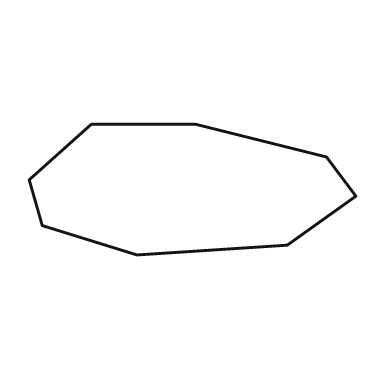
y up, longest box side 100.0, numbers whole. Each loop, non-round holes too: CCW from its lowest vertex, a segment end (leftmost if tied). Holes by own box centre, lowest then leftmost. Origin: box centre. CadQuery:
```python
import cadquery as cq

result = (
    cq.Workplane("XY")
    .moveTo(-17.0, -20.0)
    .lineTo(29.0, -17.0)
    .lineTo(50.0, -2.0)
    .lineTo(41.0, 10.0)
    .lineTo(1.0, 20.0)
    .lineTo(-31.0, 20.0)
    .lineTo(-50.0, 3.0)
    .lineTo(-46.0, -11.0)
    .close()
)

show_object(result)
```